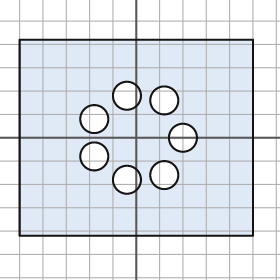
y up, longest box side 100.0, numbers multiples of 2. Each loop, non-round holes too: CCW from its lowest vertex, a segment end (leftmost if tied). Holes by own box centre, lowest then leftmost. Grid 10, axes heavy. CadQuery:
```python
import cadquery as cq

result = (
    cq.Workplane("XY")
    .moveTo(-50.0, -42.0)
    .lineTo(50.0, -42.0)
    .lineTo(50.0, 42.0)
    .lineTo(-50.0, 42.0)
    .close()
    .moveTo(-4.0, -18.0)
    .circle(6.0)
    .moveTo(12.0, -16.0)
    .circle(6.0)
    .moveTo(-18.0, -8.0)
    .circle(6.0)
    .moveTo(20.0, 0.0)
    .circle(6.0)
    .moveTo(-18.0, 8.0)
    .circle(6.0)
    .moveTo(12.0, 16.0)
    .circle(6.0)
    .moveTo(-4.0, 18.0)
    .circle(6.0)
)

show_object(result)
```